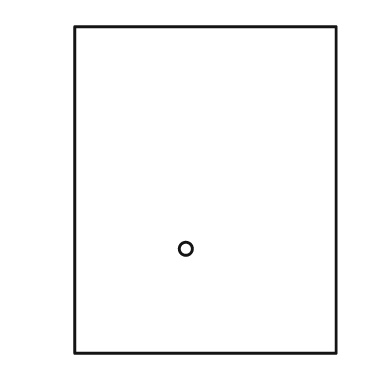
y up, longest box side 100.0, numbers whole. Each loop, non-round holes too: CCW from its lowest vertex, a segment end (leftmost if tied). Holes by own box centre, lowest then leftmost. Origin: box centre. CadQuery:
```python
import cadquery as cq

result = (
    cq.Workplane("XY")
    .moveTo(-40.0, -50.0)
    .lineTo(40.0, -50.0)
    .lineTo(40.0, 50.0)
    .lineTo(-40.0, 50.0)
    .close()
    .moveTo(-6.0, -18.0)
    .circle(2.0)
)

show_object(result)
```